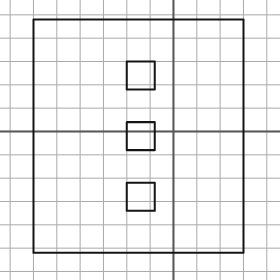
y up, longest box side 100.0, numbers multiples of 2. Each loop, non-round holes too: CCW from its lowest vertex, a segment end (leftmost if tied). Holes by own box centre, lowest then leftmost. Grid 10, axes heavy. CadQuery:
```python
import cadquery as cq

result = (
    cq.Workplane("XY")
    .moveTo(-60.0, -52.0)
    .lineTo(30.0, -52.0)
    .lineTo(30.0, 48.0)
    .lineTo(-60.0, 48.0)
    .close()
    .moveTo(-20.0, -34.0)
    .lineTo(-8.0, -34.0)
    .lineTo(-8.0, -22.0)
    .lineTo(-20.0, -22.0)
    .close()
    .moveTo(-20.0, -8.0)
    .lineTo(-8.0, -8.0)
    .lineTo(-8.0, 4.0)
    .lineTo(-20.0, 4.0)
    .close()
    .moveTo(-20.0, 18.0)
    .lineTo(-8.0, 18.0)
    .lineTo(-8.0, 30.0)
    .lineTo(-20.0, 30.0)
    .close()
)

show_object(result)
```